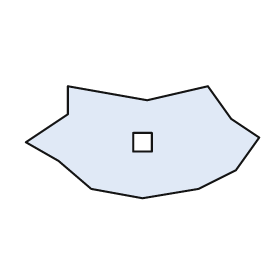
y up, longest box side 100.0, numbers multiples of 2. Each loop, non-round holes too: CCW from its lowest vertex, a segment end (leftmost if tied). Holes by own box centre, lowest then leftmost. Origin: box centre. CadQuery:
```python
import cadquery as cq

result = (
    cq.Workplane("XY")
    .moveTo(0.0, -24.0)
    .lineTo(24.0, -20.0)
    .lineTo(40.0, -12.0)
    .lineTo(50.0, 2.0)
    .lineTo(38.0, 10.0)
    .lineTo(28.0, 24.0)
    .lineTo(2.0, 18.0)
    .lineTo(-32.0, 24.0)
    .lineTo(-32.0, 12.0)
    .lineTo(-50.0, 0.0)
    .lineTo(-36.0, -8.0)
    .lineTo(-22.0, -20.0)
    .close()
    .moveTo(-4.0, -4.0)
    .lineTo(4.0, -4.0)
    .lineTo(4.0, 4.0)
    .lineTo(-4.0, 4.0)
    .close()
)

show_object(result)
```